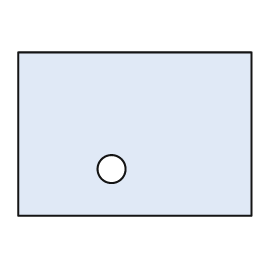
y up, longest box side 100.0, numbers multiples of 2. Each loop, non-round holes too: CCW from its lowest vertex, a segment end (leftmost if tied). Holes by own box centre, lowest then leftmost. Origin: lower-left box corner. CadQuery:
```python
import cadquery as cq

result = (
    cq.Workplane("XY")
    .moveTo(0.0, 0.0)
    .lineTo(100.0, 0.0)
    .lineTo(100.0, 70.0)
    .lineTo(0.0, 70.0)
    .close()
    .moveTo(40.0, 20.0)
    .circle(6.0)
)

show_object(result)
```